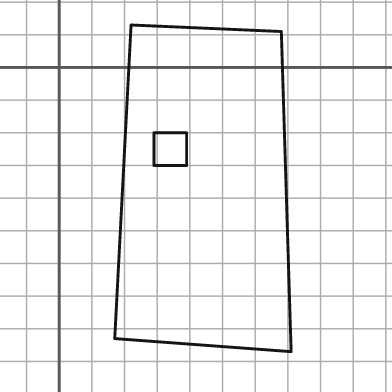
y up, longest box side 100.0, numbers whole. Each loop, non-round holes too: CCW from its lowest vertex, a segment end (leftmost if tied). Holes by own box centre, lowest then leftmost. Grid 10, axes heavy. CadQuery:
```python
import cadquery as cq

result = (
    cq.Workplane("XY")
    .moveTo(71.0, -87.0)
    .lineTo(68.0, 11.0)
    .lineTo(22.0, 13.0)
    .lineTo(17.0, -83.0)
    .close()
    .moveTo(29.0, -30.0)
    .lineTo(39.0, -30.0)
    .lineTo(39.0, -20.0)
    .lineTo(29.0, -20.0)
    .close()
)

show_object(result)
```